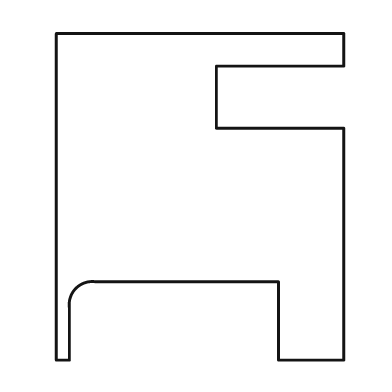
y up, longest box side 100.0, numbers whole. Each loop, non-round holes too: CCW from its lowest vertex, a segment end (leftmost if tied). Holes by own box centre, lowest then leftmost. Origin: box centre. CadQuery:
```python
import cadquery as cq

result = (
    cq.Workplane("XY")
    .moveTo(-44.0, -50.0)
    .lineTo(-40.0, -50.0)
    .lineTo(-40.0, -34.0)
    .threePointArc((-38.0, -28.0), (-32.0, -26.0))
    .lineTo(24.0, -26.0)
    .lineTo(24.0, -50.0)
    .lineTo(44.0, -50.0)
    .lineTo(44.0, 21.0)
    .lineTo(5.0, 21.0)
    .lineTo(5.0, 40.0)
    .lineTo(44.0, 40.0)
    .lineTo(44.0, 50.0)
    .lineTo(-44.0, 50.0)
    .close()
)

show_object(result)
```